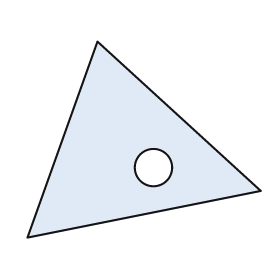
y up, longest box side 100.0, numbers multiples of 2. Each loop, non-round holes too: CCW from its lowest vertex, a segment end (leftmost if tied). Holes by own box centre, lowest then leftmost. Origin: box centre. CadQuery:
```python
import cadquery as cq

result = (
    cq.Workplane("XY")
    .moveTo(-50.0, -42.0)
    .lineTo(50.0, -22.0)
    .lineTo(-20.0, 42.0)
    .close()
    .moveTo(4.0, -12.0)
    .circle(8.0)
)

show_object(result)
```